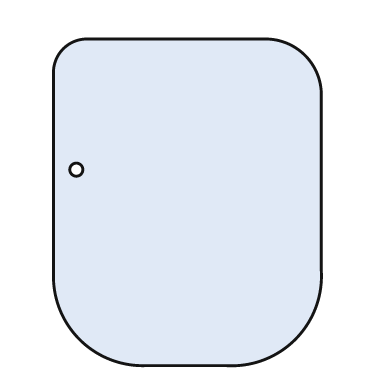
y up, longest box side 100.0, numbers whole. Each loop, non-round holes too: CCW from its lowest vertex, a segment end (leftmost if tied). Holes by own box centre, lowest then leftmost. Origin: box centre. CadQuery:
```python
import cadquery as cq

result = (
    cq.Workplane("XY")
    .moveTo(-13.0, -50.0)
    .lineTo(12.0, -50.0)
    .threePointArc((33.0, -42.0), (41.0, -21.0))
    .lineTo(41.0, 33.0)
    .threePointArc((36.0, 45.0), (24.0, 50.0))
    .lineTo(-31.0, 50.0)
    .threePointArc((-38.0, 47.0), (-41.0, 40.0))
    .lineTo(-41.0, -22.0)
    .threePointArc((-33.0, -42.0), (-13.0, -50.0))
    .close()
    .moveTo(-34.0, 10.0)
    .circle(2.0)
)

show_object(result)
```